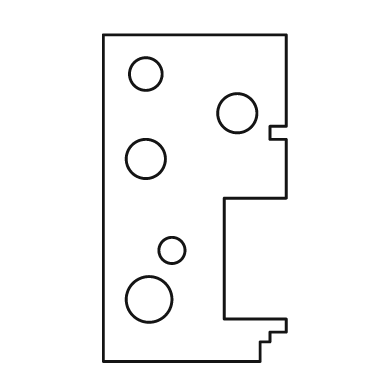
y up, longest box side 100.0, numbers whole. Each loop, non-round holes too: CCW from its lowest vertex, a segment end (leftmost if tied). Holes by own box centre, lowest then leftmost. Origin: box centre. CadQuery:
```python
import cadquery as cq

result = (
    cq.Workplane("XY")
    .moveTo(-28.0, -50.0)
    .lineTo(20.0, -50.0)
    .lineTo(20.0, -44.0)
    .lineTo(23.0, -44.0)
    .lineTo(23.0, -41.0)
    .lineTo(28.0, -41.0)
    .lineTo(28.0, -37.0)
    .lineTo(9.0, -37.0)
    .lineTo(9.0, 0.0)
    .lineTo(28.0, 0.0)
    .lineTo(28.0, 18.0)
    .lineTo(23.0, 18.0)
    .lineTo(23.0, 22.0)
    .lineTo(28.0, 22.0)
    .lineTo(28.0, 50.0)
    .lineTo(-28.0, 50.0)
    .close()
    .moveTo(-14.0, -31.0)
    .circle(7.0)
    .moveTo(-7.0, -16.0)
    .circle(4.0)
    .moveTo(-15.0, 12.0)
    .circle(6.0)
    .moveTo(13.0, 26.0)
    .circle(6.0)
    .moveTo(-15.0, 38.0)
    .circle(5.0)
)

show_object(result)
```